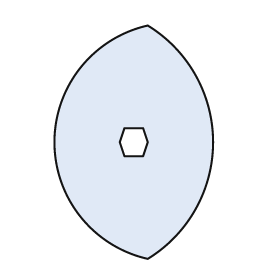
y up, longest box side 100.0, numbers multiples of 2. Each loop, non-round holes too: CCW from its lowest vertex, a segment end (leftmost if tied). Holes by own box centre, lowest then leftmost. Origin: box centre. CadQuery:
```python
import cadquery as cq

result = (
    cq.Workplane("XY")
    .moveTo(6.0, -50.0)
    .threePointArc((34.0, 0.0), (6.0, 50.0))
    .threePointArc((-34.0, 0.0), (6.0, -50.0))
    .close()
    .moveTo(-4.0, -6.0)
    .lineTo(4.0, -6.0)
    .lineTo(6.0, 0.0)
    .lineTo(4.0, 6.0)
    .lineTo(-4.0, 6.0)
    .lineTo(-6.0, 0.0)
    .close()
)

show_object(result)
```